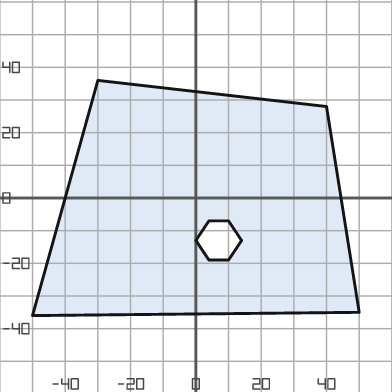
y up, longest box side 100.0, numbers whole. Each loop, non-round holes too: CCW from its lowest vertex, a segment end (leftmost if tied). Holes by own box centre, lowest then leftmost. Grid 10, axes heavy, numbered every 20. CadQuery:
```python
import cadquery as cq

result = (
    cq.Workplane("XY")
    .moveTo(-50.0, -36.0)
    .lineTo(50.0, -35.0)
    .lineTo(40.0, 28.0)
    .lineTo(-30.0, 36.0)
    .close()
    .moveTo(4.0, -19.0)
    .lineTo(10.0, -19.0)
    .lineTo(14.0, -13.0)
    .lineTo(10.0, -7.0)
    .lineTo(4.0, -7.0)
    .lineTo(0.0, -13.0)
    .close()
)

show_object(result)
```